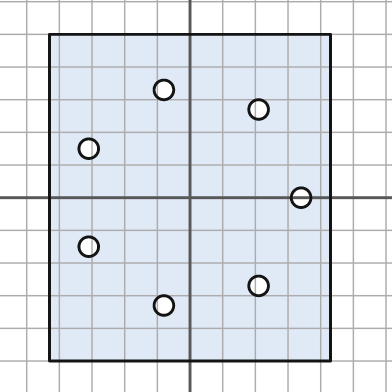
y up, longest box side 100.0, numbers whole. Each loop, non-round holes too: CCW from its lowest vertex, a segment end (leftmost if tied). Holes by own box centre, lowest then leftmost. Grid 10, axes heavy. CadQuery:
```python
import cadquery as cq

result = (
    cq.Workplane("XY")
    .moveTo(-43.0, -50.0)
    .lineTo(43.0, -50.0)
    .lineTo(43.0, 50.0)
    .lineTo(-43.0, 50.0)
    .close()
    .moveTo(-8.0, -33.0)
    .circle(3.0)
    .moveTo(21.0, -27.0)
    .circle(3.0)
    .moveTo(-31.0, -15.0)
    .circle(3.0)
    .moveTo(34.0, 0.0)
    .circle(3.0)
    .moveTo(-31.0, 15.0)
    .circle(3.0)
    .moveTo(21.0, 27.0)
    .circle(3.0)
    .moveTo(-8.0, 33.0)
    .circle(3.0)
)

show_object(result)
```